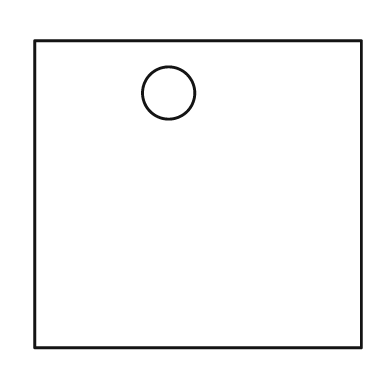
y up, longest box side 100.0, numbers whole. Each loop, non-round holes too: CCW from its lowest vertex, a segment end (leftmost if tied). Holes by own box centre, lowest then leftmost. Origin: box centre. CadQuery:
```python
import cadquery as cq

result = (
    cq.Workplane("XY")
    .moveTo(-50.0, -47.0)
    .lineTo(50.0, -47.0)
    .lineTo(50.0, 47.0)
    .lineTo(-50.0, 47.0)
    .close()
    .moveTo(-9.0, 31.0)
    .circle(8.0)
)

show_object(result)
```